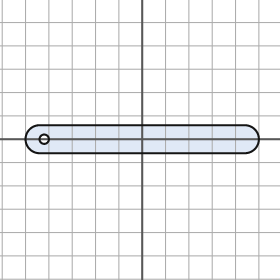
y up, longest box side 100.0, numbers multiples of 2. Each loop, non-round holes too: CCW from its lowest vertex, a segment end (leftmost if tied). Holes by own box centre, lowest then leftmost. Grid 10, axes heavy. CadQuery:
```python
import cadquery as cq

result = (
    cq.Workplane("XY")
    .moveTo(-44.0, -6.0)
    .lineTo(44.0, -6.0)
    .threePointArc((50.0, 0.0), (44.0, 6.0))
    .lineTo(-44.0, 6.0)
    .threePointArc((-50.0, 0.0), (-44.0, -6.0))
    .close()
    .moveTo(-42.0, 0.0)
    .circle(2.0)
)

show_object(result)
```